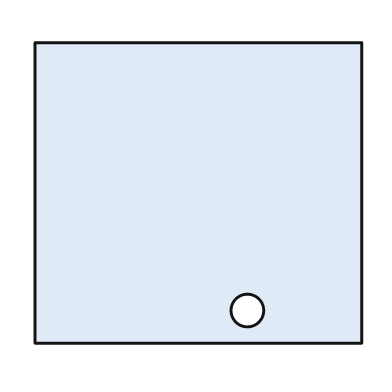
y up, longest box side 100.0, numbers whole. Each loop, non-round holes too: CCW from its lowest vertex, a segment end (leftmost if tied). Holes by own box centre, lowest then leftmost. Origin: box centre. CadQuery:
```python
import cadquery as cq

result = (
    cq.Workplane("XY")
    .moveTo(-50.0, -46.0)
    .lineTo(50.0, -46.0)
    .lineTo(50.0, 46.0)
    .lineTo(-50.0, 46.0)
    .close()
    .moveTo(15.0, -36.0)
    .circle(5.0)
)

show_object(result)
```